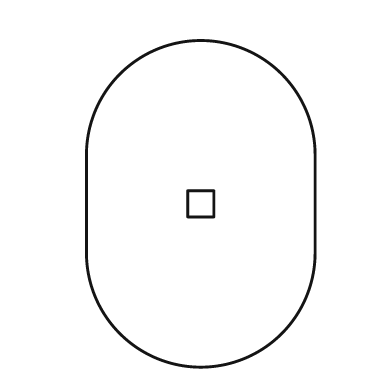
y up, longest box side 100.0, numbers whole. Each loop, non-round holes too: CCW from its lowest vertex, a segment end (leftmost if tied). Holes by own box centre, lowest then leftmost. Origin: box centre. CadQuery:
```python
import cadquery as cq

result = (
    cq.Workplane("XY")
    .moveTo(-35.0, -15.0)
    .threePointArc((0.0, -50.0), (35.0, -15.0))
    .lineTo(35.0, 15.0)
    .threePointArc((0.0, 50.0), (-35.0, 15.0))
    .close()
    .moveTo(-4.0, -4.0)
    .lineTo(4.0, -4.0)
    .lineTo(4.0, 4.0)
    .lineTo(-4.0, 4.0)
    .close()
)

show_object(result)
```